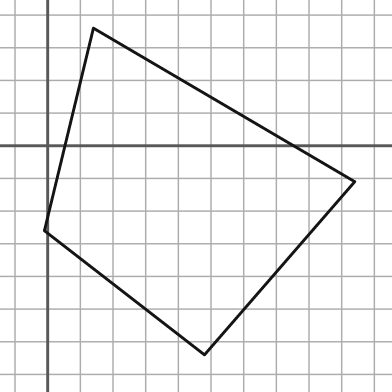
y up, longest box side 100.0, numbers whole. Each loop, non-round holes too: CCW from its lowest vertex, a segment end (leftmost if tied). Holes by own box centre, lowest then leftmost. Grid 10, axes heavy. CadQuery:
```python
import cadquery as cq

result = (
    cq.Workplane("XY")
    .moveTo(48.0, -64.0)
    .lineTo(94.0, -11.0)
    .lineTo(14.0, 36.0)
    .lineTo(-1.0, -26.0)
    .close()
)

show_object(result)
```